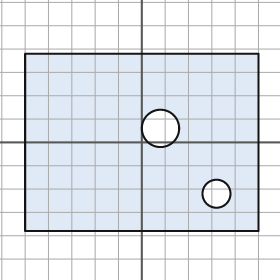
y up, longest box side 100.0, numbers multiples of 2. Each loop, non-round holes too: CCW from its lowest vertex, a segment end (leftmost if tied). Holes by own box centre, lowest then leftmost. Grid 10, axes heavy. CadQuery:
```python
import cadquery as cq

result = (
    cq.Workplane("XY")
    .moveTo(-50.0, -38.0)
    .lineTo(50.0, -38.0)
    .lineTo(50.0, 38.0)
    .lineTo(-50.0, 38.0)
    .close()
    .moveTo(32.0, -22.0)
    .circle(6.0)
    .moveTo(8.0, 6.0)
    .circle(8.0)
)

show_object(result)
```